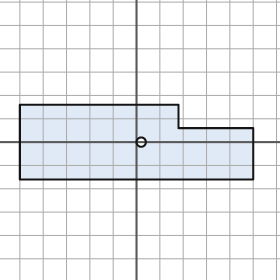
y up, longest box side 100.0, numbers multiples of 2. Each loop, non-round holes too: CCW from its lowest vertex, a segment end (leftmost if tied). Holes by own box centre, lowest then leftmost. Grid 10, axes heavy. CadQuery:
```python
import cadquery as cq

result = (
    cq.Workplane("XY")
    .moveTo(-50.0, -16.0)
    .lineTo(50.0, -16.0)
    .lineTo(50.0, 6.0)
    .lineTo(18.0, 6.0)
    .lineTo(18.0, 16.0)
    .lineTo(-50.0, 16.0)
    .close()
    .moveTo(2.0, 0.0)
    .circle(2.0)
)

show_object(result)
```